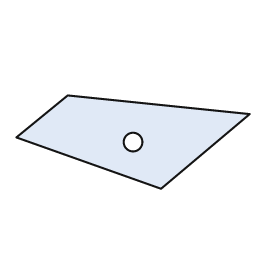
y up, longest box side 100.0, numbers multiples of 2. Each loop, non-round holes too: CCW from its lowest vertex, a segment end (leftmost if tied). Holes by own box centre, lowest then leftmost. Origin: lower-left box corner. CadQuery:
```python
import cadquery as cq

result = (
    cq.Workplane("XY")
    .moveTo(62.0, 0.0)
    .lineTo(100.0, 32.0)
    .lineTo(22.0, 40.0)
    .lineTo(0.0, 22.0)
    .close()
    .moveTo(50.0, 20.0)
    .circle(4.0)
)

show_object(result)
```